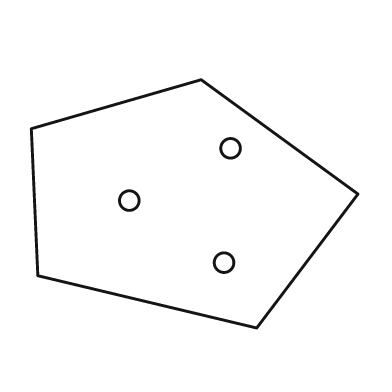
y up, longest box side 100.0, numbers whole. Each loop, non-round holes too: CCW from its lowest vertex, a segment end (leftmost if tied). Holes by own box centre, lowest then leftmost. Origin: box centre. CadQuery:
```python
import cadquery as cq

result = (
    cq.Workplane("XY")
    .moveTo(19.0, -38.0)
    .lineTo(50.0, 3.0)
    .lineTo(2.0, 38.0)
    .lineTo(-50.0, 23.0)
    .lineTo(-48.0, -22.0)
    .close()
    .moveTo(9.0, -18.0)
    .circle(3.0)
    .moveTo(-20.0, 1.0)
    .circle(3.0)
    .moveTo(11.0, 17.0)
    .circle(3.0)
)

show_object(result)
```